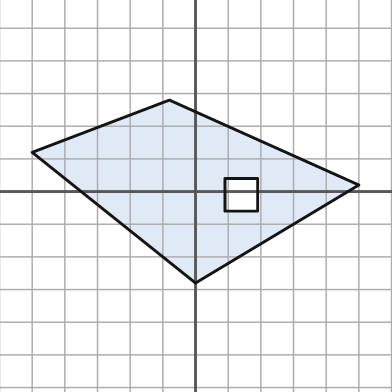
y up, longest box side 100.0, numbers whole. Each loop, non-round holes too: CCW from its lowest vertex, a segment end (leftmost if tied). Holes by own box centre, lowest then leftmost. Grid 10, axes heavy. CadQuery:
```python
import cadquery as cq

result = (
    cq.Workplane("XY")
    .moveTo(0.0, -28.0)
    .lineTo(50.0, 2.0)
    .lineTo(-8.0, 28.0)
    .lineTo(-50.0, 12.0)
    .close()
    .moveTo(9.0, -6.0)
    .lineTo(19.0, -6.0)
    .lineTo(19.0, 4.0)
    .lineTo(9.0, 4.0)
    .close()
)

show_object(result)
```